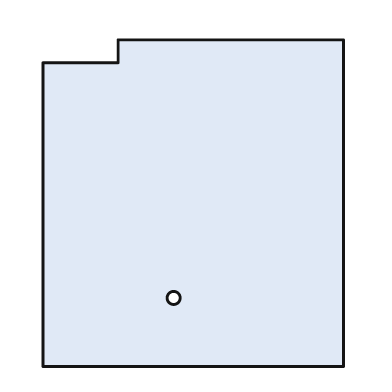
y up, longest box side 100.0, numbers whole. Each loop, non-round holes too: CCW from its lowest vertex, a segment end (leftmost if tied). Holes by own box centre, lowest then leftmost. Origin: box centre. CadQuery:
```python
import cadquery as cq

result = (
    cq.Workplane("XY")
    .moveTo(-46.0, -50.0)
    .lineTo(46.0, -50.0)
    .lineTo(46.0, 50.0)
    .lineTo(-23.0, 50.0)
    .lineTo(-23.0, 43.0)
    .lineTo(-46.0, 43.0)
    .close()
    .moveTo(-6.0, -29.0)
    .circle(2.0)
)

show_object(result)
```